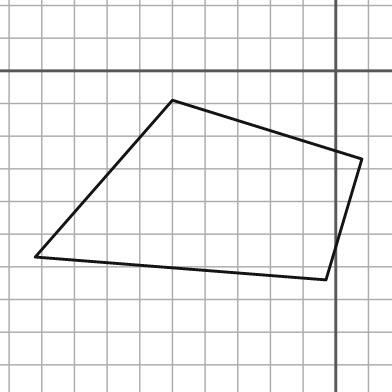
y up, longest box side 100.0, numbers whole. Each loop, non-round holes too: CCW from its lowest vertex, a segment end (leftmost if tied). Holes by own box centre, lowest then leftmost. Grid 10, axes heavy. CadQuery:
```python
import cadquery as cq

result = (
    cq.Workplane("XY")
    .moveTo(-3.0, -64.0)
    .lineTo(8.0, -27.0)
    .lineTo(-50.0, -9.0)
    .lineTo(-92.0, -57.0)
    .close()
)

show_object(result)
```